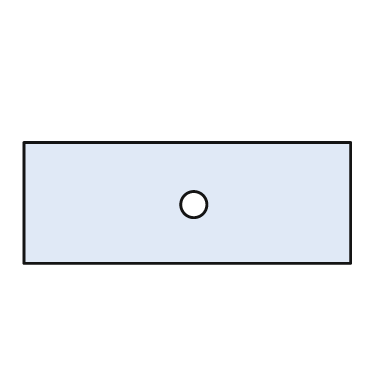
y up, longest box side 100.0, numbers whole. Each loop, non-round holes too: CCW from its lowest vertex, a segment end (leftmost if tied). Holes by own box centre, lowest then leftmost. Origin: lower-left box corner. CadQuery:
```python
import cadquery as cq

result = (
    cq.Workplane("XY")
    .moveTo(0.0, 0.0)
    .lineTo(100.0, 0.0)
    .lineTo(100.0, 37.0)
    .lineTo(0.0, 37.0)
    .close()
    .moveTo(52.0, 18.0)
    .circle(4.0)
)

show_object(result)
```